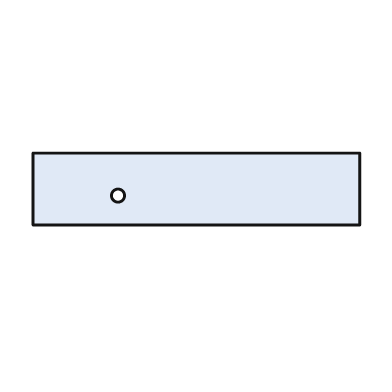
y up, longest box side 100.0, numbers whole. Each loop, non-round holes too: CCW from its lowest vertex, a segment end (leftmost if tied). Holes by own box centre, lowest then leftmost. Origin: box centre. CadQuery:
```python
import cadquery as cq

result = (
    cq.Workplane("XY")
    .moveTo(-50.0, -11.0)
    .lineTo(50.0, -11.0)
    .lineTo(50.0, 11.0)
    .lineTo(-50.0, 11.0)
    .close()
    .moveTo(-24.0, -2.0)
    .circle(2.0)
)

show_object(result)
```